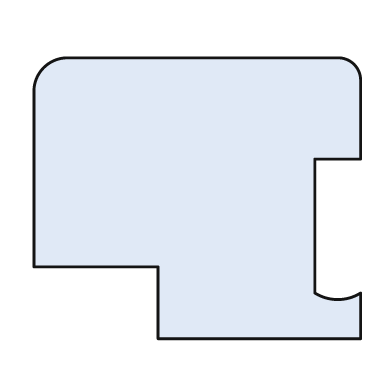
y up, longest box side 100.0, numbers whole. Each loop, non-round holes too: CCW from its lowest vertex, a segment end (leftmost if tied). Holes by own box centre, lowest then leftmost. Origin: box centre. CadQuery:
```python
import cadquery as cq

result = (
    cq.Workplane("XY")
    .moveTo(-12.0, -43.0)
    .lineTo(50.0, -43.0)
    .lineTo(50.0, -29.0)
    .threePointArc((43.0, -31.0), (36.0, -29.0))
    .lineTo(36.0, 12.0)
    .lineTo(50.0, 12.0)
    .lineTo(50.0, 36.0)
    .threePointArc((48.0, 41.0), (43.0, 43.0))
    .lineTo(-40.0, 43.0)
    .threePointArc((-47.0, 40.0), (-50.0, 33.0))
    .lineTo(-50.0, -21.0)
    .lineTo(-12.0, -21.0)
    .close()
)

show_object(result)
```